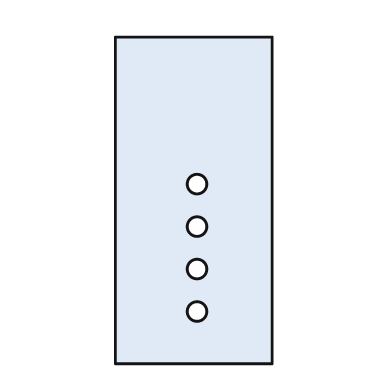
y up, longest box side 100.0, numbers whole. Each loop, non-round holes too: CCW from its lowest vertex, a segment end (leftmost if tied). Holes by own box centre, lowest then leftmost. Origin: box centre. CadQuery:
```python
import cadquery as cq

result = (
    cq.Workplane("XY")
    .moveTo(-24.0, -50.0)
    .lineTo(24.0, -50.0)
    .lineTo(24.0, 50.0)
    .lineTo(-24.0, 50.0)
    .close()
    .moveTo(1.0, -34.0)
    .circle(3.0)
    .moveTo(1.0, -21.0)
    .circle(3.0)
    .moveTo(1.0, -8.0)
    .circle(3.0)
    .moveTo(1.0, 5.0)
    .circle(3.0)
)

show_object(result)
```